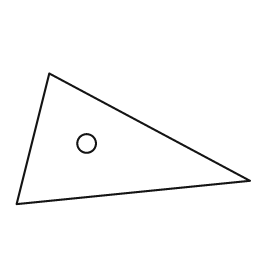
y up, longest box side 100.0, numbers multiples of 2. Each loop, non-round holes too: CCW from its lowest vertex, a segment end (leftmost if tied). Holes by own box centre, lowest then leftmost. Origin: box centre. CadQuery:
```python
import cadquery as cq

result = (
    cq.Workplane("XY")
    .moveTo(-50.0, -28.0)
    .lineTo(50.0, -18.0)
    .lineTo(-36.0, 28.0)
    .close()
    .moveTo(-20.0, -2.0)
    .circle(4.0)
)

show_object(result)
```